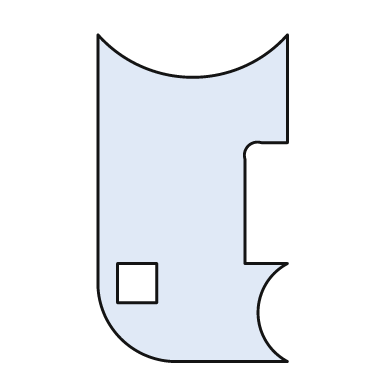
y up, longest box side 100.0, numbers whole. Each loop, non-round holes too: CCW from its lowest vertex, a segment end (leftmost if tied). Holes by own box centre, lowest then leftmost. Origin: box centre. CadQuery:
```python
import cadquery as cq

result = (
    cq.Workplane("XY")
    .moveTo(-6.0, -50.0)
    .lineTo(29.0, -50.0)
    .threePointArc((20.0, -35.0), (29.0, -20.0))
    .lineTo(16.0, -20.0)
    .lineTo(16.0, 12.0)
    .threePointArc((17.0, 16.0), (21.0, 17.0))
    .lineTo(29.0, 17.0)
    .lineTo(29.0, 50.0)
    .threePointArc((0.0, 37.0), (-29.0, 50.0))
    .lineTo(-29.0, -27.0)
    .threePointArc((-22.0, -43.0), (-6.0, -50.0))
    .close()
    .moveTo(-23.0, -32.0)
    .lineTo(-11.0, -32.0)
    .lineTo(-11.0, -20.0)
    .lineTo(-23.0, -20.0)
    .close()
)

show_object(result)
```